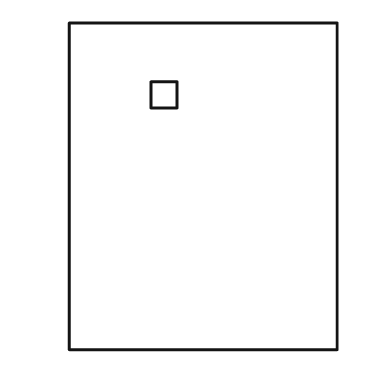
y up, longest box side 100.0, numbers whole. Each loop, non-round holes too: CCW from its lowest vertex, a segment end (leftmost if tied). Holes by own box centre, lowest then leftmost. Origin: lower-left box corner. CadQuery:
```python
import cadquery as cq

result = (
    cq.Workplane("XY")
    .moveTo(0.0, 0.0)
    .lineTo(82.0, 0.0)
    .lineTo(82.0, 100.0)
    .lineTo(0.0, 100.0)
    .close()
    .moveTo(25.0, 74.0)
    .lineTo(33.0, 74.0)
    .lineTo(33.0, 82.0)
    .lineTo(25.0, 82.0)
    .close()
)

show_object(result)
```